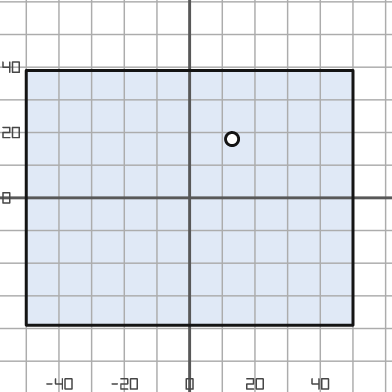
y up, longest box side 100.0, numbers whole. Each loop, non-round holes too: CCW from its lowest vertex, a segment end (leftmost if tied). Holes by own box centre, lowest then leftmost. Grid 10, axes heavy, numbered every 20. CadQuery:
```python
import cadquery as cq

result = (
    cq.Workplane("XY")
    .moveTo(-50.0, -39.0)
    .lineTo(50.0, -39.0)
    .lineTo(50.0, 39.0)
    .lineTo(-50.0, 39.0)
    .close()
    .moveTo(13.0, 18.0)
    .circle(2.0)
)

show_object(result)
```